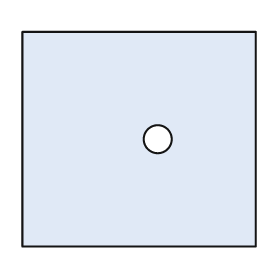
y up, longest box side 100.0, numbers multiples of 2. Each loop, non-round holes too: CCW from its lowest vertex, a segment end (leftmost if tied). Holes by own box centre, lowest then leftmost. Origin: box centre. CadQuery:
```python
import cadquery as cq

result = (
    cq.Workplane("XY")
    .moveTo(-50.0, -46.0)
    .lineTo(50.0, -46.0)
    .lineTo(50.0, 46.0)
    .lineTo(-50.0, 46.0)
    .close()
    .moveTo(8.0, 0.0)
    .circle(6.0)
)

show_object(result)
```